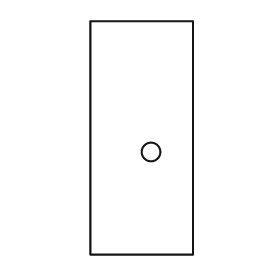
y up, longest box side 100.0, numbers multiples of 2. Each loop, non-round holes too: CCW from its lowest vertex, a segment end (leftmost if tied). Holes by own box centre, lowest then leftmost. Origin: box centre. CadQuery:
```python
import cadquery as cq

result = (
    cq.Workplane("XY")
    .moveTo(-22.0, -50.0)
    .lineTo(22.0, -50.0)
    .lineTo(22.0, 50.0)
    .lineTo(-22.0, 50.0)
    .close()
    .moveTo(4.0, -6.0)
    .circle(4.0)
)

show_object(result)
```